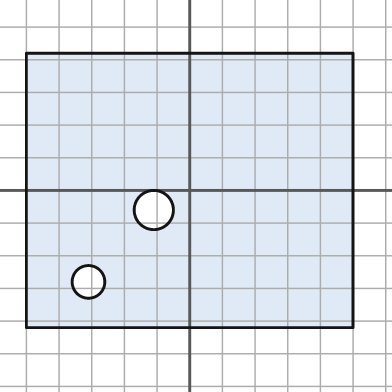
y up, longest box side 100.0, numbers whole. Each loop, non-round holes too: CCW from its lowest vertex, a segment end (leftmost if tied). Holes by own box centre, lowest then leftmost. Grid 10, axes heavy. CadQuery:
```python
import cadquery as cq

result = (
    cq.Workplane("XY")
    .moveTo(-50.0, -42.0)
    .lineTo(50.0, -42.0)
    .lineTo(50.0, 42.0)
    .lineTo(-50.0, 42.0)
    .close()
    .moveTo(-31.0, -28.0)
    .circle(5.0)
    .moveTo(-11.0, -6.0)
    .circle(6.0)
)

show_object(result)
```